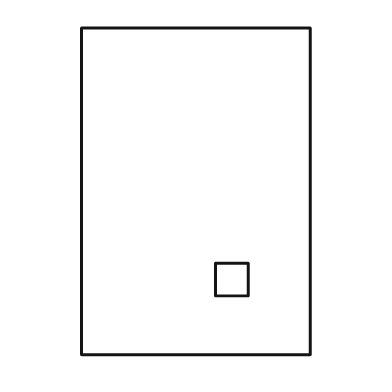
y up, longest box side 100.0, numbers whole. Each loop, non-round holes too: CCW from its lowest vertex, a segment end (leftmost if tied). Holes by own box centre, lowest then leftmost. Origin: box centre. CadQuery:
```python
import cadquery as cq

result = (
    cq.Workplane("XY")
    .moveTo(-35.0, -50.0)
    .lineTo(35.0, -50.0)
    .lineTo(35.0, 50.0)
    .lineTo(-35.0, 50.0)
    .close()
    .moveTo(6.0, -32.0)
    .lineTo(16.0, -32.0)
    .lineTo(16.0, -22.0)
    .lineTo(6.0, -22.0)
    .close()
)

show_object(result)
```